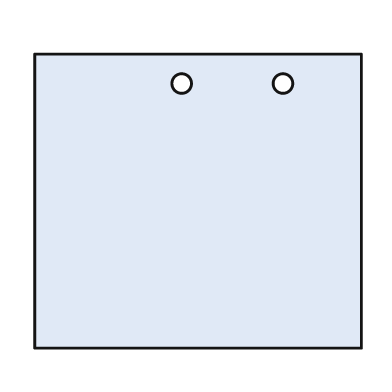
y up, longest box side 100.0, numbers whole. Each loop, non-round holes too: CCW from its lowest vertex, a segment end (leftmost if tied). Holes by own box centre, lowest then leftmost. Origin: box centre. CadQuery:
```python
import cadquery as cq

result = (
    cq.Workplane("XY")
    .moveTo(-50.0, -45.0)
    .lineTo(50.0, -45.0)
    .lineTo(50.0, 45.0)
    .lineTo(-50.0, 45.0)
    .close()
    .moveTo(-5.0, 36.0)
    .circle(3.0)
    .moveTo(26.0, 36.0)
    .circle(3.0)
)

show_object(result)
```